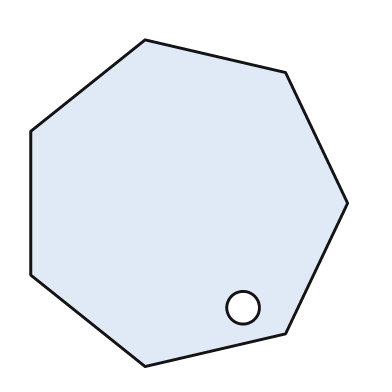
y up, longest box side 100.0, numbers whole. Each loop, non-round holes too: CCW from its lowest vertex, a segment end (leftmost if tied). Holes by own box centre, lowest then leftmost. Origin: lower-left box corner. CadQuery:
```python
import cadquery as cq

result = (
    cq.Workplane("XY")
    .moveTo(35.0, 0.0)
    .lineTo(78.0, 10.0)
    .lineTo(97.0, 50.0)
    .lineTo(78.0, 90.0)
    .lineTo(35.0, 100.0)
    .lineTo(0.0, 72.0)
    .lineTo(0.0, 28.0)
    .close()
    .moveTo(65.0, 18.0)
    .circle(5.0)
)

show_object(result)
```